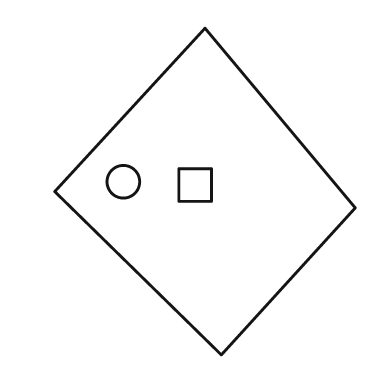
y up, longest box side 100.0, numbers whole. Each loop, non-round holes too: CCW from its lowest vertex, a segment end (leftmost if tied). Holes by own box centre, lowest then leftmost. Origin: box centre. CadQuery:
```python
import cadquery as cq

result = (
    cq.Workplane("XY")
    .moveTo(5.0, -50.0)
    .lineTo(46.0, -5.0)
    .lineTo(0.0, 50.0)
    .lineTo(-46.0, 0.0)
    .close()
    .moveTo(-8.0, -3.0)
    .lineTo(2.0, -3.0)
    .lineTo(2.0, 7.0)
    .lineTo(-8.0, 7.0)
    .close()
    .moveTo(-25.0, 3.0)
    .circle(5.0)
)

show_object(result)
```